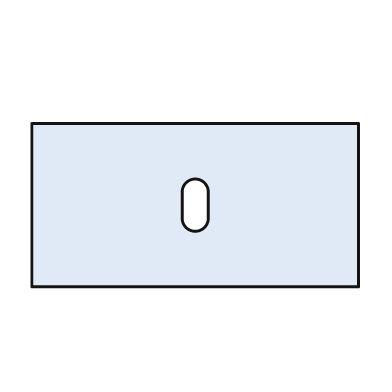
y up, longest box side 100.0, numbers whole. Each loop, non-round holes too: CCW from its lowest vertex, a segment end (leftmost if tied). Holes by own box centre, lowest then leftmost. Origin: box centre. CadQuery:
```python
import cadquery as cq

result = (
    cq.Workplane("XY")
    .moveTo(-50.0, -25.0)
    .lineTo(50.0, -25.0)
    .lineTo(50.0, 25.0)
    .lineTo(-50.0, 25.0)
    .close()
    .moveTo(-4.0, -4.0)
    .threePointArc((0.0, -8.0), (4.0, -4.0))
    .lineTo(4.0, 4.0)
    .threePointArc((0.0, 8.0), (-4.0, 4.0))
    .close()
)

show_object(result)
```